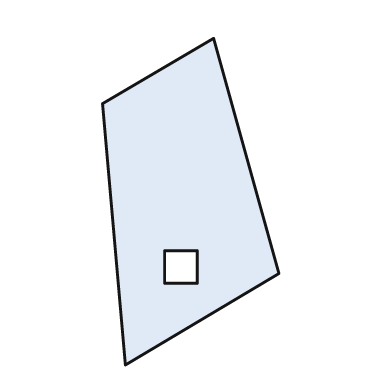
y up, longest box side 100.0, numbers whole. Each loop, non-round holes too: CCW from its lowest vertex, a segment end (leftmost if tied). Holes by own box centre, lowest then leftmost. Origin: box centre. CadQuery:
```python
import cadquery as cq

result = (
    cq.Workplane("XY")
    .moveTo(-20.0, -50.0)
    .lineTo(27.0, -22.0)
    .lineTo(7.0, 50.0)
    .lineTo(-27.0, 30.0)
    .close()
    .moveTo(-8.0, -25.0)
    .lineTo(2.0, -25.0)
    .lineTo(2.0, -15.0)
    .lineTo(-8.0, -15.0)
    .close()
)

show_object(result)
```